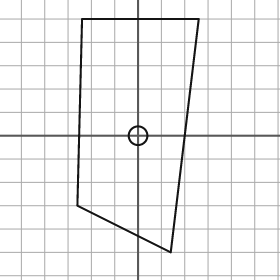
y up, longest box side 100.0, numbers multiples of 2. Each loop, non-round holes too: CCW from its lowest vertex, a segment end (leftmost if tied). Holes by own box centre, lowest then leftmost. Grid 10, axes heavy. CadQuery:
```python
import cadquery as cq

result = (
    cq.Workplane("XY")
    .moveTo(14.0, -50.0)
    .lineTo(26.0, 50.0)
    .lineTo(-24.0, 50.0)
    .lineTo(-26.0, -30.0)
    .close()
    .moveTo(0.0, 0.0)
    .circle(4.0)
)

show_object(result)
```